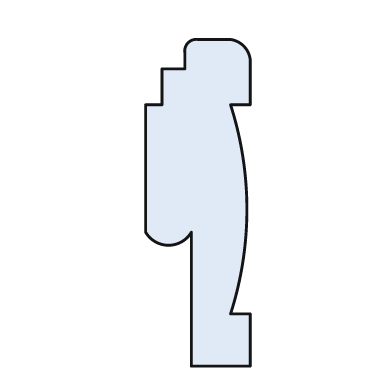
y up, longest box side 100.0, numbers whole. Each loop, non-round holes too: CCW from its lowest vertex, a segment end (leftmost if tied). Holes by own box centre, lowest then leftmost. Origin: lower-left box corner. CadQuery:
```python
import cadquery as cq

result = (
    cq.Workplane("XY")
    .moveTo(14.0, 0.0)
    .lineTo(32.0, 0.0)
    .lineTo(32.0, 16.0)
    .lineTo(26.0, 16.0)
    .threePointArc((31.0, 48.0), (26.0, 80.0))
    .lineTo(32.0, 80.0)
    .lineTo(32.0, 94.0)
    .threePointArc((30.0, 98.0), (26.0, 100.0))
    .lineTo(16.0, 100.0)
    .threePointArc((13.0, 99.0), (12.0, 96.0))
    .lineTo(12.0, 91.0)
    .lineTo(5.0, 91.0)
    .lineTo(5.0, 80.0)
    .lineTo(0.0, 80.0)
    .lineTo(0.0, 41.0)
    .threePointArc((7.0, 37.0), (14.0, 41.0))
    .close()
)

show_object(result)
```